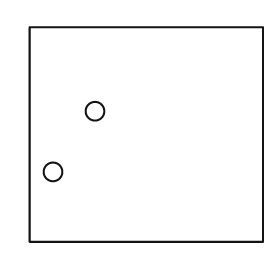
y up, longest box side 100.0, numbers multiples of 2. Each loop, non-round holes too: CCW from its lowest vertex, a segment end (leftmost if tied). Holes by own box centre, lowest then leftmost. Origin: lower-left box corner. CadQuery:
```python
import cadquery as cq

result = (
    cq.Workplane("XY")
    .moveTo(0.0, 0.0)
    .lineTo(100.0, 0.0)
    .lineTo(100.0, 92.0)
    .lineTo(0.0, 92.0)
    .close()
    .moveTo(10.0, 30.0)
    .circle(4.0)
    .moveTo(28.0, 56.0)
    .circle(4.0)
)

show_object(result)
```